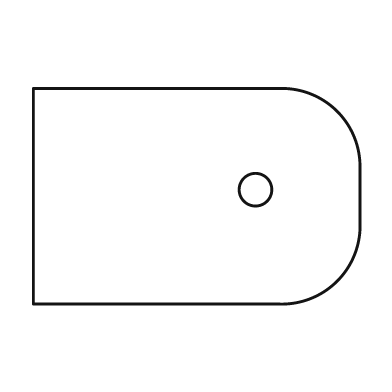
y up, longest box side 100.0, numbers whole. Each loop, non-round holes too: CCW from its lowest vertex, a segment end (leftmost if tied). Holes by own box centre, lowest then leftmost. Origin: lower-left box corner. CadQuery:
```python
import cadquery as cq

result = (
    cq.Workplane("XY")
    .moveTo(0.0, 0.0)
    .lineTo(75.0, 0.0)
    .threePointArc((93.0, 7.0), (100.0, 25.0))
    .lineTo(100.0, 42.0)
    .threePointArc((93.0, 59.0), (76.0, 66.0))
    .lineTo(0.0, 66.0)
    .close()
    .moveTo(68.0, 35.0)
    .circle(5.0)
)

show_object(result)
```